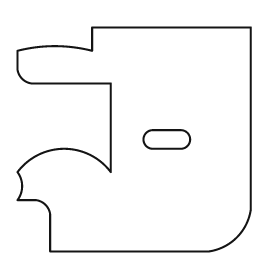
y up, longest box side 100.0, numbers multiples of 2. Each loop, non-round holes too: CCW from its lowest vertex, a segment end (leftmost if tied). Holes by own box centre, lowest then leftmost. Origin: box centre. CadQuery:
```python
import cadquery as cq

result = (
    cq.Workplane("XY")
    .moveTo(-36.0, -48.0)
    .lineTo(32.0, -48.0)
    .threePointArc((44.0, -42.0), (50.0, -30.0))
    .lineTo(50.0, 48.0)
    .lineTo(-18.0, 48.0)
    .lineTo(-18.0, 38.0)
    .threePointArc((-34.0, 40.0), (-50.0, 38.0))
    .lineTo(-50.0, 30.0)
    .threePointArc((-48.0, 26.0), (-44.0, 24.0))
    .lineTo(-10.0, 24.0)
    .lineTo(-10.0, -14.0)
    .threePointArc((-30.0, -4.0), (-50.0, -14.0))
    .threePointArc((-48.0, -20.0), (-50.0, -26.0))
    .lineTo(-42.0, -26.0)
    .threePointArc((-38.0, -28.0), (-36.0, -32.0))
    .close()
    .moveTo(8.0, -4.0)
    .lineTo(20.0, -4.0)
    .threePointArc((24.0, 0.0), (20.0, 4.0))
    .lineTo(8.0, 4.0)
    .threePointArc((4.0, 0.0), (8.0, -4.0))
    .close()
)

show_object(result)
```